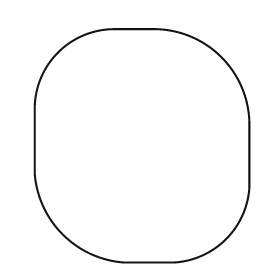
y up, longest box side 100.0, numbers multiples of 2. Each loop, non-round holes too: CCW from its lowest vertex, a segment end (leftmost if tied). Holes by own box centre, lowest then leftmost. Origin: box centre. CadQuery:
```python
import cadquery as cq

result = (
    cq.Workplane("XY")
    .moveTo(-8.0, -50.0)
    .lineTo(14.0, -50.0)
    .threePointArc((36.0, -40.0), (46.0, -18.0))
    .lineTo(46.0, 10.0)
    .threePointArc((34.0, 38.0), (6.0, 50.0))
    .lineTo(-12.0, 50.0)
    .threePointArc((-36.0, 40.0), (-46.0, 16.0))
    .lineTo(-46.0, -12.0)
    .threePointArc((-34.0, -38.0), (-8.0, -50.0))
    .close()
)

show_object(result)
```